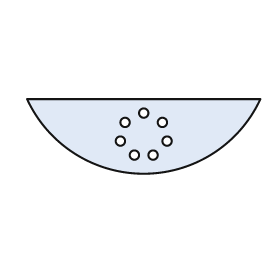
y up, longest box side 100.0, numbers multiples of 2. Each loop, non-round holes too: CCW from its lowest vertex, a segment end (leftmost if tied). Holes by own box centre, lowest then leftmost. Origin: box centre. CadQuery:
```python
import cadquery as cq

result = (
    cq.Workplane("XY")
    .moveTo(-50.0, 16.0)
    .threePointArc((0.0, -16.0), (50.0, 16.0))
    .close()
    .moveTo(-4.0, -8.0)
    .circle(2.0)
    .moveTo(4.0, -8.0)
    .circle(2.0)
    .moveTo(-10.0, -2.0)
    .circle(2.0)
    .moveTo(10.0, -2.0)
    .circle(2.0)
    .moveTo(-8.0, 6.0)
    .circle(2.0)
    .moveTo(8.0, 6.0)
    .circle(2.0)
    .moveTo(0.0, 10.0)
    .circle(2.0)
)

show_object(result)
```